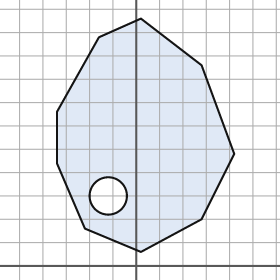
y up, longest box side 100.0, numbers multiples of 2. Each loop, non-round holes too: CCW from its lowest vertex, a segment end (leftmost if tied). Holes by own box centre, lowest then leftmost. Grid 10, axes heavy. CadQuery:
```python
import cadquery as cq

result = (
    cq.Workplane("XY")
    .moveTo(2.0, 6.0)
    .lineTo(28.0, 20.0)
    .lineTo(42.0, 48.0)
    .lineTo(28.0, 86.0)
    .lineTo(2.0, 106.0)
    .lineTo(-16.0, 98.0)
    .lineTo(-34.0, 66.0)
    .lineTo(-34.0, 44.0)
    .lineTo(-22.0, 16.0)
    .close()
    .moveTo(-12.0, 30.0)
    .circle(8.0)
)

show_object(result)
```